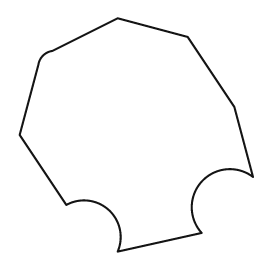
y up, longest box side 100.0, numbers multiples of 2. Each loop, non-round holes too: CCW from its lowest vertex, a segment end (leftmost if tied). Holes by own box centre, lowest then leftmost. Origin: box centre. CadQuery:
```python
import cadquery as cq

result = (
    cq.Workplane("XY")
    .moveTo(-8.0, -50.0)
    .lineTo(28.0, -42.0)
    .threePointArc((28.0, -20.0), (50.0, -18.0))
    .lineTo(42.0, 12.0)
    .lineTo(22.0, 42.0)
    .lineTo(-8.0, 50.0)
    .lineTo(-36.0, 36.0)
    .threePointArc((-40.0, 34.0), (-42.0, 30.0))
    .lineTo(-50.0, 0.0)
    .lineTo(-30.0, -30.0)
    .threePointArc((-12.0, -32.0), (-8.0, -50.0))
    .close()
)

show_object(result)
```